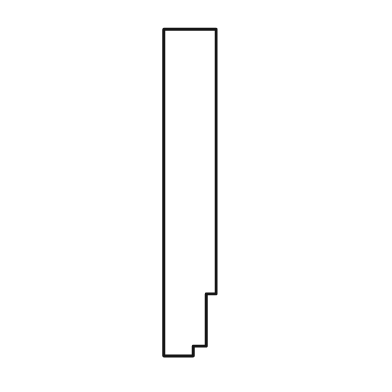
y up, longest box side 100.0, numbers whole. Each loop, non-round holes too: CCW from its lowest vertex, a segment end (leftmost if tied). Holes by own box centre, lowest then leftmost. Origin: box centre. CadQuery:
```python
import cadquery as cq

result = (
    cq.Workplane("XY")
    .moveTo(-8.0, -50.0)
    .lineTo(1.0, -50.0)
    .lineTo(1.0, -47.0)
    .lineTo(5.0, -47.0)
    .lineTo(5.0, -31.0)
    .lineTo(8.0, -31.0)
    .lineTo(8.0, 50.0)
    .lineTo(-8.0, 50.0)
    .close()
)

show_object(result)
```